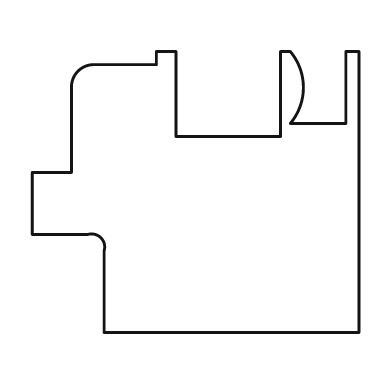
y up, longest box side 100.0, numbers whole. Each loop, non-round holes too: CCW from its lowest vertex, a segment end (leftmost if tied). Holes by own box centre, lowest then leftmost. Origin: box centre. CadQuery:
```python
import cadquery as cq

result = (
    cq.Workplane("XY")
    .moveTo(-28.0, -43.0)
    .lineTo(50.0, -43.0)
    .lineTo(50.0, 43.0)
    .lineTo(46.0, 43.0)
    .lineTo(46.0, 21.0)
    .lineTo(29.0, 21.0)
    .threePointArc((33.0, 32.0), (29.0, 43.0))
    .lineTo(26.0, 43.0)
    .lineTo(26.0, 17.0)
    .lineTo(-6.0, 17.0)
    .lineTo(-6.0, 43.0)
    .lineTo(-12.0, 43.0)
    .lineTo(-12.0, 39.0)
    .lineTo(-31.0, 39.0)
    .threePointArc((-36.0, 37.0), (-38.0, 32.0))
    .lineTo(-38.0, 6.0)
    .lineTo(-50.0, 6.0)
    .lineTo(-50.0, -13.0)
    .lineTo(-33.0, -13.0)
    .threePointArc((-29.0, -14.0), (-28.0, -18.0))
    .close()
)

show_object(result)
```